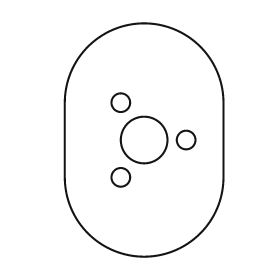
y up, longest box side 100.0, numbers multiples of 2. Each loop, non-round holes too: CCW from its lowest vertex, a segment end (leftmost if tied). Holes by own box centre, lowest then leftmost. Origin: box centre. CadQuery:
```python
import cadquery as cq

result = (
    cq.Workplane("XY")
    .moveTo(-34.0, -16.0)
    .threePointArc((0.0, -50.0), (34.0, -16.0))
    .lineTo(34.0, 16.0)
    .threePointArc((0.0, 50.0), (-34.0, 16.0))
    .close()
    .moveTo(-10.0, -16.0)
    .circle(4.0)
    .moveTo(0.0, 0.0)
    .circle(10.0)
    .moveTo(18.0, 0.0)
    .circle(4.0)
    .moveTo(-10.0, 16.0)
    .circle(4.0)
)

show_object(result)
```